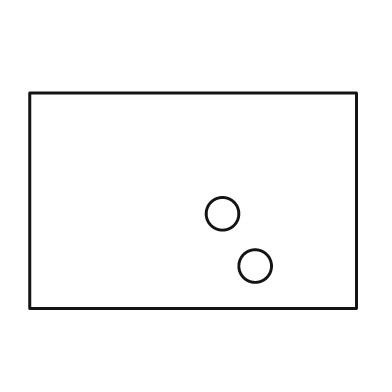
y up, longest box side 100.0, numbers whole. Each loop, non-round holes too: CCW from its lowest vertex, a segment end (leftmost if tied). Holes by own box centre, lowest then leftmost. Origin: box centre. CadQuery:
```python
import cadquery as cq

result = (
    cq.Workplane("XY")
    .moveTo(-50.0, -33.0)
    .lineTo(50.0, -33.0)
    .lineTo(50.0, 33.0)
    .lineTo(-50.0, 33.0)
    .close()
    .moveTo(19.0, -20.0)
    .circle(5.0)
    .moveTo(9.0, -4.0)
    .circle(5.0)
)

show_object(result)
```